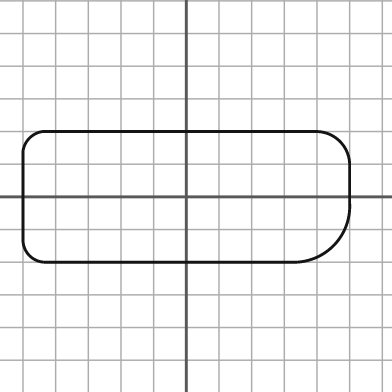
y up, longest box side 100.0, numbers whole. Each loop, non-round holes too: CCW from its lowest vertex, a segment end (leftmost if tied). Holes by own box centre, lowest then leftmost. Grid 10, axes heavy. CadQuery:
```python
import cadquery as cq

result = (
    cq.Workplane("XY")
    .moveTo(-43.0, -20.0)
    .lineTo(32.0, -20.0)
    .threePointArc((45.0, -15.0), (50.0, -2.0))
    .lineTo(50.0, 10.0)
    .threePointArc((47.0, 17.0), (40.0, 20.0))
    .lineTo(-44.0, 20.0)
    .threePointArc((-48.0, 18.0), (-50.0, 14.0))
    .lineTo(-50.0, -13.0)
    .threePointArc((-48.0, -18.0), (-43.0, -20.0))
    .close()
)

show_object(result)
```